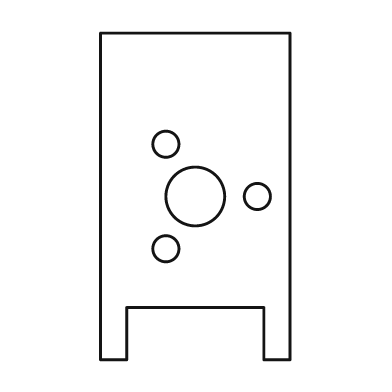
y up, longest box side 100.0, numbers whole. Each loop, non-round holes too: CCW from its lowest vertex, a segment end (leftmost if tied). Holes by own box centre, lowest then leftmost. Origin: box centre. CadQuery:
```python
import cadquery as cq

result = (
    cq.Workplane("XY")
    .moveTo(-29.0, -50.0)
    .lineTo(-21.0, -50.0)
    .lineTo(-21.0, -34.0)
    .lineTo(21.0, -34.0)
    .lineTo(21.0, -50.0)
    .lineTo(29.0, -50.0)
    .lineTo(29.0, 50.0)
    .lineTo(-29.0, 50.0)
    .close()
    .moveTo(-9.0, -16.0)
    .circle(4.0)
    .moveTo(0.0, 0.0)
    .circle(9.0)
    .moveTo(19.0, 0.0)
    .circle(4.0)
    .moveTo(-9.0, 16.0)
    .circle(4.0)
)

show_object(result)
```